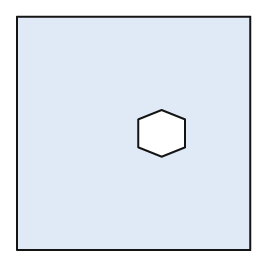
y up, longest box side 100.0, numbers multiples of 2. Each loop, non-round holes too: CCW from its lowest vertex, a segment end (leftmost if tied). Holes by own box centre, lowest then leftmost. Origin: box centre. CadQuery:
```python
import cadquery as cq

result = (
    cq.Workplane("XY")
    .moveTo(-50.0, -50.0)
    .lineTo(50.0, -50.0)
    .lineTo(50.0, 50.0)
    .lineTo(-50.0, 50.0)
    .close()
    .moveTo(12.0, -10.0)
    .lineTo(22.0, -6.0)
    .lineTo(22.0, 6.0)
    .lineTo(12.0, 10.0)
    .lineTo(2.0, 6.0)
    .lineTo(2.0, -6.0)
    .close()
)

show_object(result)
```